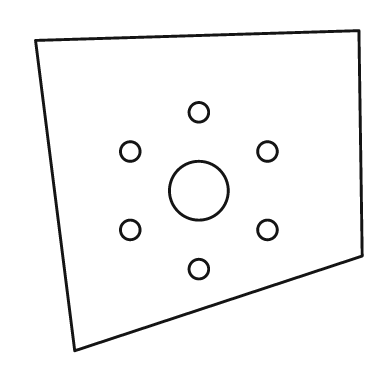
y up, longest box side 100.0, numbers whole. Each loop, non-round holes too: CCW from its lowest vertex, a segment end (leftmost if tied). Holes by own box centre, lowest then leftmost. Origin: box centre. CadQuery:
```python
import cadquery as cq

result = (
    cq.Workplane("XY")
    .moveTo(-38.0, -49.0)
    .lineTo(50.0, -20.0)
    .lineTo(49.0, 49.0)
    .lineTo(-50.0, 46.0)
    .close()
    .moveTo(0.0, -24.0)
    .circle(3.0)
    .moveTo(-21.0, -12.0)
    .circle(3.0)
    .moveTo(21.0, -12.0)
    .circle(3.0)
    .moveTo(0.0, 0.0)
    .circle(9.0)
    .moveTo(-21.0, 12.0)
    .circle(3.0)
    .moveTo(21.0, 12.0)
    .circle(3.0)
    .moveTo(0.0, 24.0)
    .circle(3.0)
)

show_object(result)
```